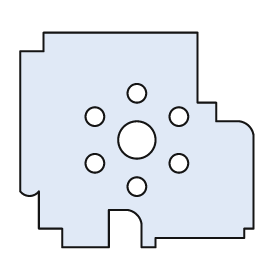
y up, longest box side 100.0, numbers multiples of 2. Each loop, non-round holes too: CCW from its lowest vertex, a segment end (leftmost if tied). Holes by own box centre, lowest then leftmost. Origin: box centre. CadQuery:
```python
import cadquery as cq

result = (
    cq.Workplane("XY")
    .moveTo(-32.0, -46.0)
    .lineTo(-12.0, -46.0)
    .lineTo(-12.0, -30.0)
    .lineTo(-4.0, -30.0)
    .threePointArc((0.0, -32.0), (2.0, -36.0))
    .lineTo(2.0, -46.0)
    .lineTo(8.0, -46.0)
    .lineTo(8.0, -42.0)
    .lineTo(46.0, -42.0)
    .lineTo(46.0, -38.0)
    .lineTo(50.0, -38.0)
    .lineTo(50.0, 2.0)
    .threePointArc((48.0, 6.0), (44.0, 8.0))
    .lineTo(34.0, 8.0)
    .lineTo(34.0, 16.0)
    .lineTo(26.0, 16.0)
    .lineTo(26.0, 46.0)
    .lineTo(-40.0, 46.0)
    .lineTo(-40.0, 38.0)
    .lineTo(-50.0, 38.0)
    .lineTo(-50.0, -22.0)
    .threePointArc((-46.0, -24.0), (-42.0, -22.0))
    .lineTo(-42.0, -38.0)
    .lineTo(-32.0, -38.0)
    .close()
    .moveTo(0.0, -20.0)
    .circle(4.0)
    .moveTo(-18.0, -10.0)
    .circle(4.0)
    .moveTo(18.0, -10.0)
    .circle(4.0)
    .moveTo(0.0, 0.0)
    .circle(8.0)
    .moveTo(-18.0, 10.0)
    .circle(4.0)
    .moveTo(18.0, 10.0)
    .circle(4.0)
    .moveTo(0.0, 20.0)
    .circle(4.0)
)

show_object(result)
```